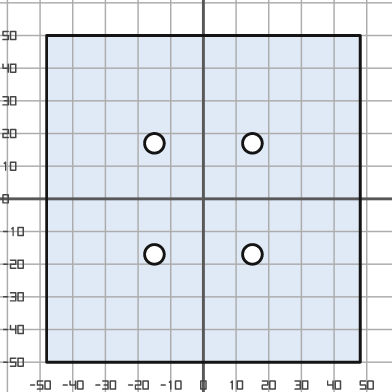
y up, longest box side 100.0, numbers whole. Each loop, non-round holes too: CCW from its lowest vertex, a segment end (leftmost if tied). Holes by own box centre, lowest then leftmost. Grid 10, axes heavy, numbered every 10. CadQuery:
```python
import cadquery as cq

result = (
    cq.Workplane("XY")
    .moveTo(-48.0, -50.0)
    .lineTo(48.0, -50.0)
    .lineTo(48.0, 50.0)
    .lineTo(-48.0, 50.0)
    .close()
    .moveTo(-15.0, -17.0)
    .circle(3.0)
    .moveTo(15.0, -17.0)
    .circle(3.0)
    .moveTo(-15.0, 17.0)
    .circle(3.0)
    .moveTo(15.0, 17.0)
    .circle(3.0)
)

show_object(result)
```